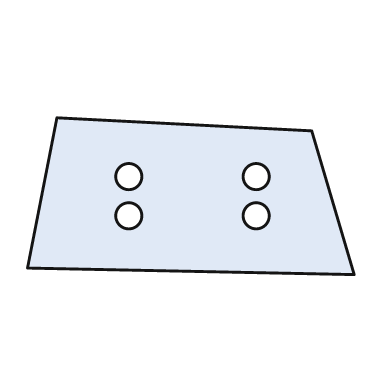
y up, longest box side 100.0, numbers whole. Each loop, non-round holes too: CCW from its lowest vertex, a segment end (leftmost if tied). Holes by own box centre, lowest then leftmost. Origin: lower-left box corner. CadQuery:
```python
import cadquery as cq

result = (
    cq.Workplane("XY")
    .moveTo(100.0, 0.0)
    .lineTo(87.0, 44.0)
    .lineTo(9.0, 48.0)
    .lineTo(0.0, 2.0)
    .close()
    .moveTo(31.0, 18.0)
    .circle(4.0)
    .moveTo(70.0, 18.0)
    .circle(4.0)
    .moveTo(31.0, 30.0)
    .circle(4.0)
    .moveTo(70.0, 30.0)
    .circle(4.0)
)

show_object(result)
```